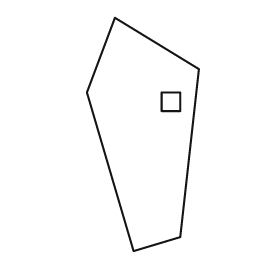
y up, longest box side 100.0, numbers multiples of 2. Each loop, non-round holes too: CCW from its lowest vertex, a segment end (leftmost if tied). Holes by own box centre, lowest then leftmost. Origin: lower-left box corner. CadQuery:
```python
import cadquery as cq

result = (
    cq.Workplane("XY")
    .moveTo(20.0, 0.0)
    .lineTo(40.0, 6.0)
    .lineTo(48.0, 78.0)
    .lineTo(12.0, 100.0)
    .lineTo(0.0, 68.0)
    .close()
    .moveTo(32.0, 60.0)
    .lineTo(40.0, 60.0)
    .lineTo(40.0, 68.0)
    .lineTo(32.0, 68.0)
    .close()
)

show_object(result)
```